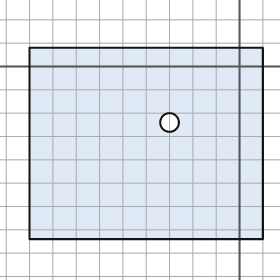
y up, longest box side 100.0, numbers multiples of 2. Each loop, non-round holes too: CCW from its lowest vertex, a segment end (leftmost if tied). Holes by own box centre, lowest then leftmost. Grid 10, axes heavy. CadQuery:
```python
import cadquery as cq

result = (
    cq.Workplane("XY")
    .moveTo(-90.0, -74.0)
    .lineTo(10.0, -74.0)
    .lineTo(10.0, 8.0)
    .lineTo(-90.0, 8.0)
    .close()
    .moveTo(-30.0, -24.0)
    .circle(4.0)
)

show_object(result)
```